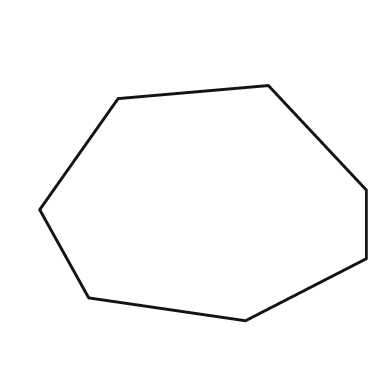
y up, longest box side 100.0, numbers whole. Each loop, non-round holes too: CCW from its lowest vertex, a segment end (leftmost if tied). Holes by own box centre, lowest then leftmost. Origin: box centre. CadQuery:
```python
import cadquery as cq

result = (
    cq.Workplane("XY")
    .moveTo(13.0, -36.0)
    .lineTo(50.0, -17.0)
    .lineTo(50.0, 4.0)
    .lineTo(20.0, 36.0)
    .lineTo(-26.0, 32.0)
    .lineTo(-50.0, -2.0)
    .lineTo(-35.0, -29.0)
    .close()
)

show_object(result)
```